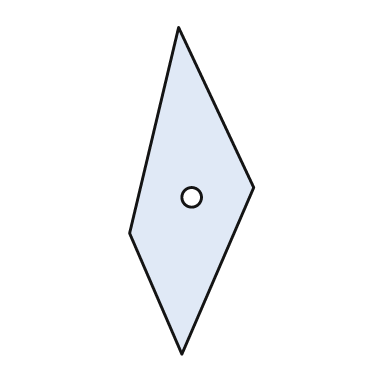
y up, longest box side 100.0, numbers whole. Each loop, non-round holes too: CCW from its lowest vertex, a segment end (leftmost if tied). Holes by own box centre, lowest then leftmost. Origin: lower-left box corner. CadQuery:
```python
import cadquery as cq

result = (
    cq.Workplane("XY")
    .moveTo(16.0, 0.0)
    .lineTo(38.0, 51.0)
    .lineTo(15.0, 100.0)
    .lineTo(0.0, 37.0)
    .close()
    .moveTo(19.0, 48.0)
    .circle(3.0)
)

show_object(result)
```